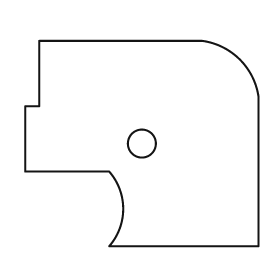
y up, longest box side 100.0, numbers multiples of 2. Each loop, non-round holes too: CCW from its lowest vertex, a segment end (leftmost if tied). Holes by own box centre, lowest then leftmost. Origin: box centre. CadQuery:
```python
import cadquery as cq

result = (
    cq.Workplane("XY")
    .moveTo(-14.0, -44.0)
    .lineTo(50.0, -44.0)
    .lineTo(50.0, 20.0)
    .threePointArc((42.0, 36.0), (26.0, 44.0))
    .lineTo(-44.0, 44.0)
    .lineTo(-44.0, 16.0)
    .lineTo(-50.0, 16.0)
    .lineTo(-50.0, -12.0)
    .lineTo(-14.0, -12.0)
    .threePointArc((-8.0, -28.0), (-14.0, -44.0))
    .close()
    .moveTo(0.0, 0.0)
    .circle(6.0)
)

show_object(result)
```